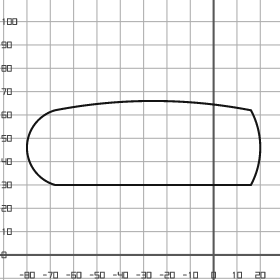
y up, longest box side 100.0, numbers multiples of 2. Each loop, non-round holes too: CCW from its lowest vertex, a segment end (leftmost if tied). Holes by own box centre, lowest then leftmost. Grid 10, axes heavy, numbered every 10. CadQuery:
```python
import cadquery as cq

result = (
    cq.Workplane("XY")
    .moveTo(-68.0, 30.0)
    .lineTo(16.0, 30.0)
    .threePointArc((20.0, 46.0), (16.0, 62.0))
    .threePointArc((-26.0, 66.0), (-68.0, 62.0))
    .threePointArc((-80.0, 46.0), (-68.0, 30.0))
    .close()
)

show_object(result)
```